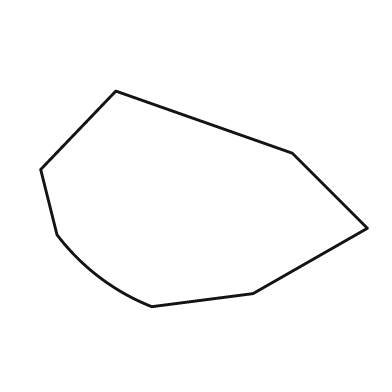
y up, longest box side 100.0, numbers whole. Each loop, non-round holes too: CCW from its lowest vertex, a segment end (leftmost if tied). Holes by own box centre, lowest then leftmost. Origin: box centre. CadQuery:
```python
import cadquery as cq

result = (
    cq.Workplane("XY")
    .moveTo(-16.0, -33.0)
    .lineTo(15.0, -29.0)
    .lineTo(50.0, -9.0)
    .lineTo(27.0, 14.0)
    .lineTo(-27.0, 33.0)
    .lineTo(-50.0, 9.0)
    .lineTo(-45.0, -11.0)
    .threePointArc((-32.0, -24.0), (-16.0, -33.0))
    .close()
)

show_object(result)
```